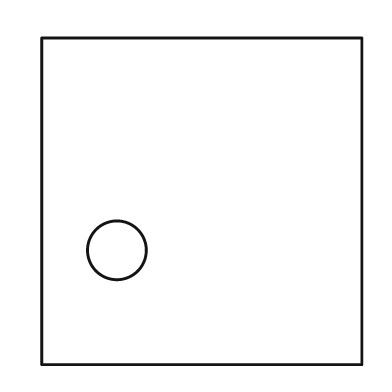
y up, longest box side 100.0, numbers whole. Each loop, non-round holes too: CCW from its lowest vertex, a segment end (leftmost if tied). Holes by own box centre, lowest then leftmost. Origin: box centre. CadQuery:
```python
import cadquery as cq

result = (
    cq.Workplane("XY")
    .moveTo(-49.0, -50.0)
    .lineTo(49.0, -50.0)
    .lineTo(49.0, 50.0)
    .lineTo(-49.0, 50.0)
    .close()
    .moveTo(-26.0, -15.0)
    .circle(9.0)
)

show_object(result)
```